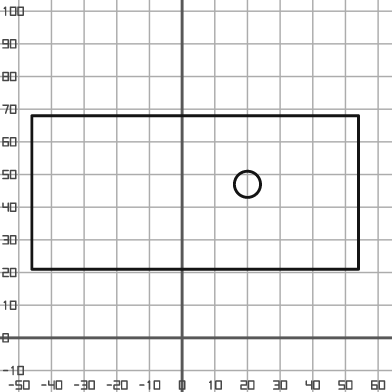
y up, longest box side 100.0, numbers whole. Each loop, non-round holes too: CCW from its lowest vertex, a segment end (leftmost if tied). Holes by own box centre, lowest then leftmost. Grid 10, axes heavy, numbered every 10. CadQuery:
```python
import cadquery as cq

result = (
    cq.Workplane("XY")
    .moveTo(-46.0, 21.0)
    .lineTo(54.0, 21.0)
    .lineTo(54.0, 68.0)
    .lineTo(-46.0, 68.0)
    .close()
    .moveTo(20.0, 47.0)
    .circle(4.0)
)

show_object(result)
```